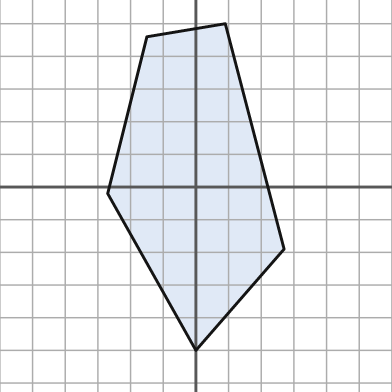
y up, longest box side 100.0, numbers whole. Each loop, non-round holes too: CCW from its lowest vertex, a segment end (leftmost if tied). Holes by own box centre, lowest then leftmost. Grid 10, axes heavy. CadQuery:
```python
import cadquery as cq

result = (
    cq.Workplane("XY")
    .moveTo(0.0, -50.0)
    .lineTo(27.0, -19.0)
    .lineTo(9.0, 50.0)
    .lineTo(-15.0, 46.0)
    .lineTo(-27.0, -2.0)
    .close()
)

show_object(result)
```